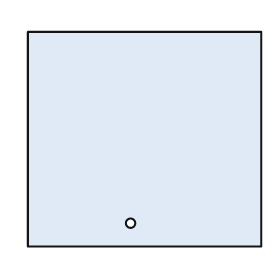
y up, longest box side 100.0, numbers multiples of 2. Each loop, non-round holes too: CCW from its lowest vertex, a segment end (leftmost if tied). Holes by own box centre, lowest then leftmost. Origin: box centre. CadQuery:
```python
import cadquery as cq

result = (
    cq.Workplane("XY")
    .moveTo(-50.0, -46.0)
    .lineTo(50.0, -46.0)
    .lineTo(50.0, 46.0)
    .lineTo(-50.0, 46.0)
    .close()
    .moveTo(-6.0, -36.0)
    .circle(2.0)
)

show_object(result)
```